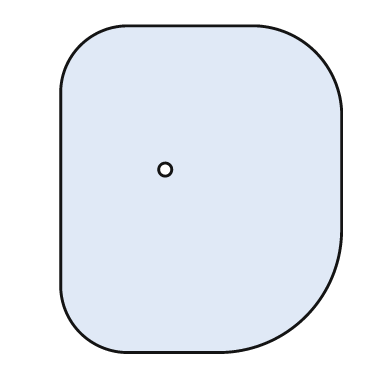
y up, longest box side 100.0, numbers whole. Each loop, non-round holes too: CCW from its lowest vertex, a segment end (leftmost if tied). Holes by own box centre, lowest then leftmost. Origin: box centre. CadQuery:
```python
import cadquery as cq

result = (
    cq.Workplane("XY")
    .moveTo(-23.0, -50.0)
    .lineTo(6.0, -50.0)
    .threePointArc((32.0, -39.0), (43.0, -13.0))
    .lineTo(43.0, 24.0)
    .threePointArc((35.0, 42.0), (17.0, 50.0))
    .lineTo(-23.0, 50.0)
    .threePointArc((-37.0, 44.0), (-43.0, 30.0))
    .lineTo(-43.0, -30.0)
    .threePointArc((-37.0, -44.0), (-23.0, -50.0))
    .close()
    .moveTo(-11.0, 6.0)
    .circle(2.0)
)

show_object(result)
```